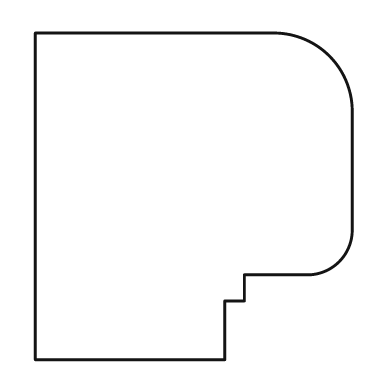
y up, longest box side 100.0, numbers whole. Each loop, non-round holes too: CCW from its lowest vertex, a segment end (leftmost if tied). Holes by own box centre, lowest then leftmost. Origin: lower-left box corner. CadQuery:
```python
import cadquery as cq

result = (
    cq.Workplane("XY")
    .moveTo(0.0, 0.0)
    .lineTo(58.0, 0.0)
    .lineTo(58.0, 18.0)
    .lineTo(64.0, 18.0)
    .lineTo(64.0, 26.0)
    .lineTo(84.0, 26.0)
    .threePointArc((93.0, 30.0), (97.0, 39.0))
    .lineTo(97.0, 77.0)
    .threePointArc((90.0, 93.0), (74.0, 100.0))
    .lineTo(0.0, 100.0)
    .close()
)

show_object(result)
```